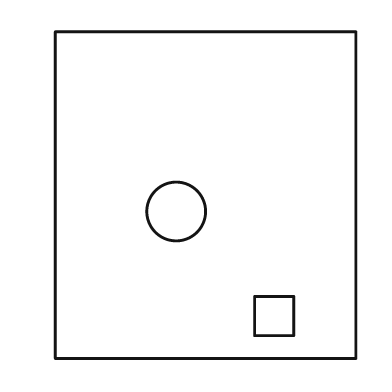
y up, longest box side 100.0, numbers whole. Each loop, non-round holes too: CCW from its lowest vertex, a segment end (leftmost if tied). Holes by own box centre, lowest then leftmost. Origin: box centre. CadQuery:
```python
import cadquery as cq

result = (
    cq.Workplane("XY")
    .moveTo(-46.0, -50.0)
    .lineTo(46.0, -50.0)
    .lineTo(46.0, 50.0)
    .lineTo(-46.0, 50.0)
    .close()
    .moveTo(15.0, -43.0)
    .lineTo(27.0, -43.0)
    .lineTo(27.0, -31.0)
    .lineTo(15.0, -31.0)
    .close()
    .moveTo(-9.0, -5.0)
    .circle(9.0)
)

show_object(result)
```